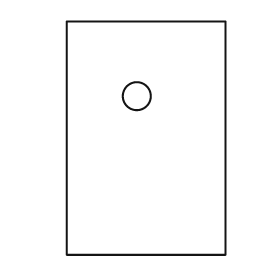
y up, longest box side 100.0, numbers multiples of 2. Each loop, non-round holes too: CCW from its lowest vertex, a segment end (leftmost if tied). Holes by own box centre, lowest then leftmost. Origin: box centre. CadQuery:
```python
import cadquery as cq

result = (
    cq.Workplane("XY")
    .moveTo(-34.0, -50.0)
    .lineTo(34.0, -50.0)
    .lineTo(34.0, 50.0)
    .lineTo(-34.0, 50.0)
    .close()
    .moveTo(-4.0, 18.0)
    .circle(6.0)
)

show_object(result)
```